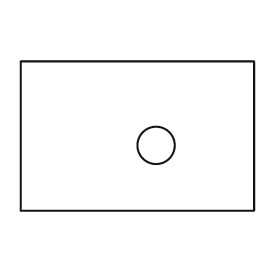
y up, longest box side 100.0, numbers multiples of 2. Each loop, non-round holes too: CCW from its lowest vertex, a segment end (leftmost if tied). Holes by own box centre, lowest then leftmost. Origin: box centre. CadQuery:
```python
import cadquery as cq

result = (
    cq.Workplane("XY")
    .moveTo(-50.0, -32.0)
    .lineTo(50.0, -32.0)
    .lineTo(50.0, 32.0)
    .lineTo(-50.0, 32.0)
    .close()
    .moveTo(8.0, -4.0)
    .circle(8.0)
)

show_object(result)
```